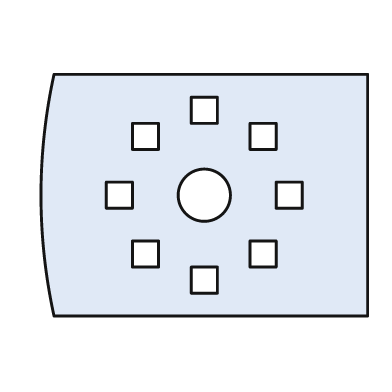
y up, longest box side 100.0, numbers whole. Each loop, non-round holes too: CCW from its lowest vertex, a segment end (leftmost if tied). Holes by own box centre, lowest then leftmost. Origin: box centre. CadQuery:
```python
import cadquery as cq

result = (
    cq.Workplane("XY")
    .moveTo(-46.0, -37.0)
    .lineTo(50.0, -37.0)
    .lineTo(50.0, 37.0)
    .lineTo(-46.0, 37.0)
    .threePointArc((-50.0, 0.0), (-46.0, -37.0))
    .close()
    .moveTo(-4.0, -30.0)
    .lineTo(4.0, -30.0)
    .lineTo(4.0, -22.0)
    .lineTo(-4.0, -22.0)
    .close()
    .moveTo(-22.0, -22.0)
    .lineTo(-14.0, -22.0)
    .lineTo(-14.0, -14.0)
    .lineTo(-22.0, -14.0)
    .close()
    .moveTo(14.0, -22.0)
    .lineTo(22.0, -22.0)
    .lineTo(22.0, -14.0)
    .lineTo(14.0, -14.0)
    .close()
    .moveTo(-30.0, -4.0)
    .lineTo(-22.0, -4.0)
    .lineTo(-22.0, 4.0)
    .lineTo(-30.0, 4.0)
    .close()
    .moveTo(0.0, 0.0)
    .circle(8.0)
    .moveTo(22.0, -4.0)
    .lineTo(30.0, -4.0)
    .lineTo(30.0, 4.0)
    .lineTo(22.0, 4.0)
    .close()
    .moveTo(-22.0, 14.0)
    .lineTo(-14.0, 14.0)
    .lineTo(-14.0, 22.0)
    .lineTo(-22.0, 22.0)
    .close()
    .moveTo(14.0, 14.0)
    .lineTo(22.0, 14.0)
    .lineTo(22.0, 22.0)
    .lineTo(14.0, 22.0)
    .close()
    .moveTo(-4.0, 22.0)
    .lineTo(4.0, 22.0)
    .lineTo(4.0, 30.0)
    .lineTo(-4.0, 30.0)
    .close()
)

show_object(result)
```